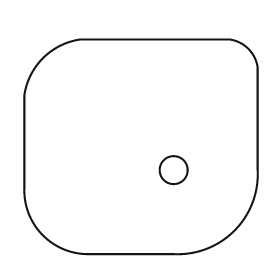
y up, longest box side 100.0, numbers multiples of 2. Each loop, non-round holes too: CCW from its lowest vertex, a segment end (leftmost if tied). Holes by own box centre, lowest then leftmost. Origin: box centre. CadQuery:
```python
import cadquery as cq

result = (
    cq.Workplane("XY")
    .moveTo(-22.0, -46.0)
    .lineTo(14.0, -46.0)
    .threePointArc((40.0, -36.0), (50.0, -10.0))
    .lineTo(50.0, 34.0)
    .threePointArc((46.0, 42.0), (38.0, 46.0))
    .lineTo(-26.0, 46.0)
    .threePointArc((-42.0, 38.0), (-50.0, 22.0))
    .lineTo(-50.0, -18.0)
    .threePointArc((-42.0, -38.0), (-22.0, -46.0))
    .close()
    .moveTo(14.0, -10.0)
    .circle(6.0)
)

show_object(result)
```